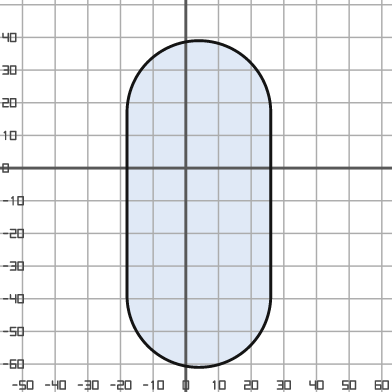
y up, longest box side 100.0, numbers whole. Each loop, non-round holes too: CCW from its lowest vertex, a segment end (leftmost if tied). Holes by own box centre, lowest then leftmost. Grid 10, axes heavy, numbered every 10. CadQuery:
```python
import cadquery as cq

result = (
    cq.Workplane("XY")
    .moveTo(-18.0, -39.0)
    .threePointArc((4.0, -61.0), (26.0, -39.0))
    .lineTo(26.0, 17.0)
    .threePointArc((4.0, 39.0), (-18.0, 17.0))
    .close()
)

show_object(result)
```